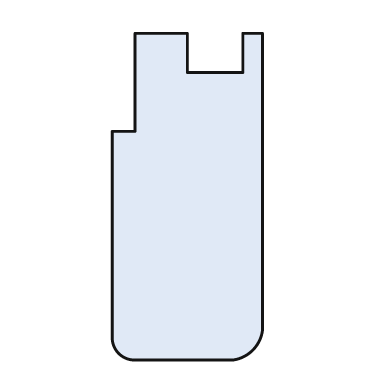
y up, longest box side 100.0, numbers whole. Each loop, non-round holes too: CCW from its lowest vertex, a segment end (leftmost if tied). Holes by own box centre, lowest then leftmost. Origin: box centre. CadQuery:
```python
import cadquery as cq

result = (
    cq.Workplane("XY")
    .moveTo(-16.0, -50.0)
    .lineTo(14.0, -50.0)
    .threePointArc((20.0, -47.0), (23.0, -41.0))
    .lineTo(23.0, 50.0)
    .lineTo(17.0, 50.0)
    .lineTo(17.0, 38.0)
    .lineTo(0.0, 38.0)
    .lineTo(0.0, 50.0)
    .lineTo(-16.0, 50.0)
    .lineTo(-16.0, 20.0)
    .lineTo(-23.0, 20.0)
    .lineTo(-23.0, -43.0)
    .threePointArc((-21.0, -48.0), (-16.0, -50.0))
    .close()
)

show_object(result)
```